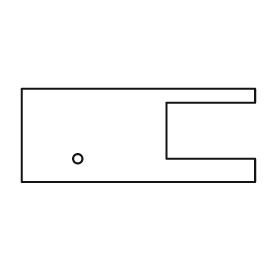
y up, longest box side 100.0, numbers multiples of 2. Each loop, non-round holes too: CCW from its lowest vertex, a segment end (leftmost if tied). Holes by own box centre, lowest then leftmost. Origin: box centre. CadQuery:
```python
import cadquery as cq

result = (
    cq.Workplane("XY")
    .moveTo(-50.0, -20.0)
    .lineTo(50.0, -20.0)
    .lineTo(50.0, -10.0)
    .lineTo(12.0, -10.0)
    .lineTo(12.0, 14.0)
    .lineTo(50.0, 14.0)
    .lineTo(50.0, 20.0)
    .lineTo(-50.0, 20.0)
    .close()
    .moveTo(-26.0, -10.0)
    .circle(2.0)
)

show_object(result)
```